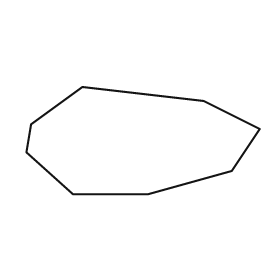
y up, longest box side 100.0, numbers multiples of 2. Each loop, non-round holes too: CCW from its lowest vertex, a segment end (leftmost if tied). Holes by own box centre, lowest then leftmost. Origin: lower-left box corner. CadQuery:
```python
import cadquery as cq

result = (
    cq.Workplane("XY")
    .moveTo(20.0, 0.0)
    .lineTo(52.0, 0.0)
    .lineTo(88.0, 10.0)
    .lineTo(100.0, 28.0)
    .lineTo(76.0, 40.0)
    .lineTo(24.0, 46.0)
    .lineTo(2.0, 30.0)
    .lineTo(0.0, 18.0)
    .close()
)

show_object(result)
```